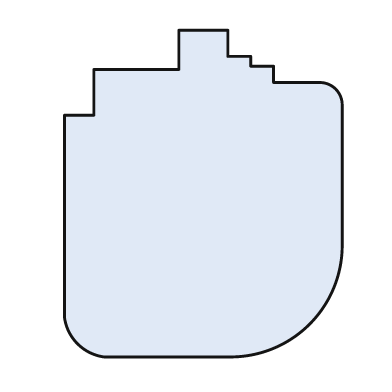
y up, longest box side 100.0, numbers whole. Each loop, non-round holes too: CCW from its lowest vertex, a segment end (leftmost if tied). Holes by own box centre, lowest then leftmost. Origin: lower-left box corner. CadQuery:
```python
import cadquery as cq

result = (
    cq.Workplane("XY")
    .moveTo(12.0, 0.0)
    .lineTo(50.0, 0.0)
    .threePointArc((75.0, 10.0), (85.0, 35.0))
    .lineTo(85.0, 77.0)
    .threePointArc((83.0, 82.0), (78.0, 84.0))
    .lineTo(64.0, 84.0)
    .lineTo(64.0, 89.0)
    .lineTo(57.0, 89.0)
    .lineTo(57.0, 92.0)
    .lineTo(50.0, 92.0)
    .lineTo(50.0, 100.0)
    .lineTo(35.0, 100.0)
    .lineTo(35.0, 88.0)
    .lineTo(9.0, 88.0)
    .lineTo(9.0, 74.0)
    .lineTo(0.0, 74.0)
    .lineTo(0.0, 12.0)
    .threePointArc((4.0, 4.0), (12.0, 0.0))
    .close()
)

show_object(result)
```